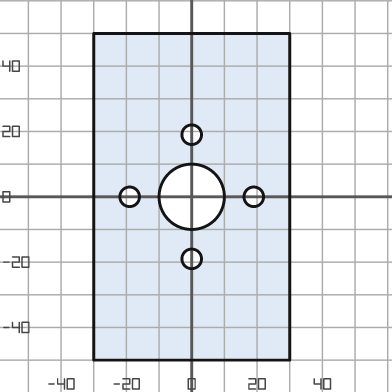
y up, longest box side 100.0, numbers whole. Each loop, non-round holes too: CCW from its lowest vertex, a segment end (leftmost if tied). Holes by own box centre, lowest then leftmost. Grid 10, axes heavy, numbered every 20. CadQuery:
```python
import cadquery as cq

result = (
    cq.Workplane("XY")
    .moveTo(-30.0, -50.0)
    .lineTo(30.0, -50.0)
    .lineTo(30.0, 50.0)
    .lineTo(-30.0, 50.0)
    .close()
    .moveTo(0.0, -19.0)
    .circle(3.0)
    .moveTo(-19.0, 0.0)
    .circle(3.0)
    .moveTo(0.0, 0.0)
    .circle(10.0)
    .moveTo(19.0, 0.0)
    .circle(3.0)
    .moveTo(0.0, 19.0)
    .circle(3.0)
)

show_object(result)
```